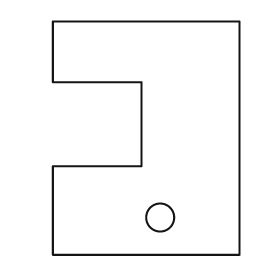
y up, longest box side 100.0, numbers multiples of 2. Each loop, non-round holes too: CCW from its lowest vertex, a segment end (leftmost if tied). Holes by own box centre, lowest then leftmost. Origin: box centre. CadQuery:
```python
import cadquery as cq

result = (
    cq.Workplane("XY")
    .moveTo(-40.0, -50.0)
    .lineTo(40.0, -50.0)
    .lineTo(40.0, 50.0)
    .lineTo(-40.0, 50.0)
    .lineTo(-40.0, 24.0)
    .lineTo(-2.0, 24.0)
    .lineTo(-2.0, -12.0)
    .lineTo(-40.0, -12.0)
    .close()
    .moveTo(6.0, -34.0)
    .circle(6.0)
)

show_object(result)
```